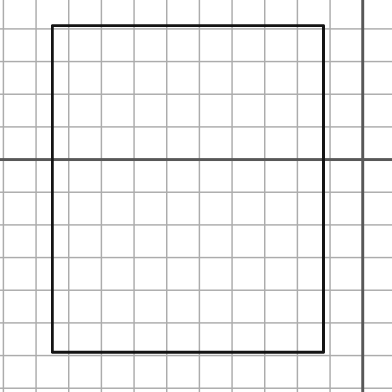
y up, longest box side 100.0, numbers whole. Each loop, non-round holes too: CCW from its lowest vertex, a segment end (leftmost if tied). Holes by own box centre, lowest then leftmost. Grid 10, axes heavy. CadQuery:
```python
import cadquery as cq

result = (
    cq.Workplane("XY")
    .moveTo(-95.0, -59.0)
    .lineTo(-12.0, -59.0)
    .lineTo(-12.0, 41.0)
    .lineTo(-95.0, 41.0)
    .close()
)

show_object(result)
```